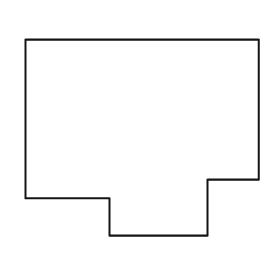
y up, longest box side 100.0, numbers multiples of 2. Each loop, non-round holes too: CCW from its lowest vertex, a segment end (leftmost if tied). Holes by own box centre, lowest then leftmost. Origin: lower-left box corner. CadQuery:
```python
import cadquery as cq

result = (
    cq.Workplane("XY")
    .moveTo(36.0, 0.0)
    .lineTo(78.0, 0.0)
    .lineTo(78.0, 24.0)
    .lineTo(100.0, 24.0)
    .lineTo(100.0, 84.0)
    .lineTo(0.0, 84.0)
    .lineTo(0.0, 16.0)
    .lineTo(36.0, 16.0)
    .close()
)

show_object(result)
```